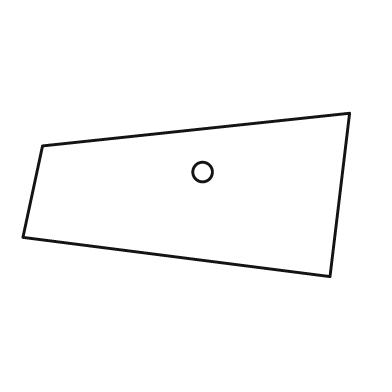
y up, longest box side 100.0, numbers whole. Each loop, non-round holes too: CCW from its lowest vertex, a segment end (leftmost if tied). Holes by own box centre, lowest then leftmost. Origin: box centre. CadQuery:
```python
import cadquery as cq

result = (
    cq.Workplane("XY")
    .moveTo(44.0, -25.0)
    .lineTo(50.0, 25.0)
    .lineTo(-44.0, 15.0)
    .lineTo(-50.0, -13.0)
    .close()
    .moveTo(5.0, 7.0)
    .circle(3.0)
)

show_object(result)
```